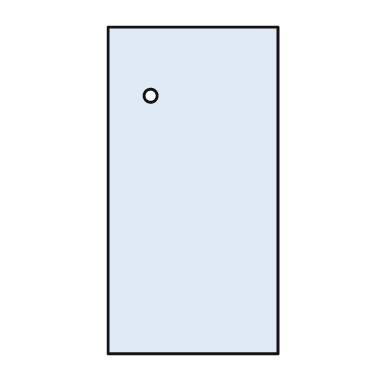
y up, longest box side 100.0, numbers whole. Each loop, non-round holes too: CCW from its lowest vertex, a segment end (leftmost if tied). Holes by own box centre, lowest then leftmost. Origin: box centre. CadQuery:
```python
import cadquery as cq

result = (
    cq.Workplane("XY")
    .moveTo(-26.0, -50.0)
    .lineTo(26.0, -50.0)
    .lineTo(26.0, 50.0)
    .lineTo(-26.0, 50.0)
    .close()
    .moveTo(-13.0, 29.0)
    .circle(2.0)
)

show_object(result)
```